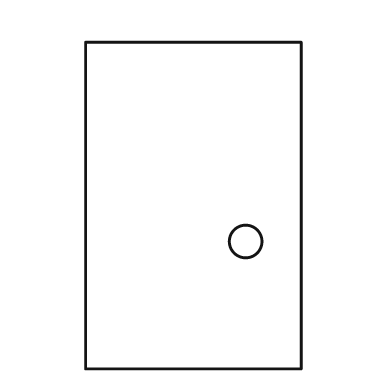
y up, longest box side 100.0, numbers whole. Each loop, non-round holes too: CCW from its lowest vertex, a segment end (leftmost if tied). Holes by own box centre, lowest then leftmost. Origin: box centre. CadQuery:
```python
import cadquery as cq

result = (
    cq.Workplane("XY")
    .moveTo(-33.0, -50.0)
    .lineTo(33.0, -50.0)
    .lineTo(33.0, 50.0)
    .lineTo(-33.0, 50.0)
    .close()
    .moveTo(16.0, -11.0)
    .circle(5.0)
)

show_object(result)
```